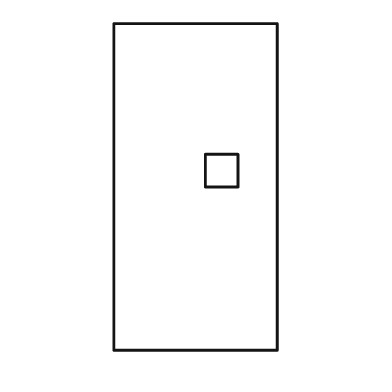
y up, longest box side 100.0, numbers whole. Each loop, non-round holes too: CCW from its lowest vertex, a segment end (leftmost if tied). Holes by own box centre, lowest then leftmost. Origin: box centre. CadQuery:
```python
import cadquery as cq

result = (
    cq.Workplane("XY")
    .moveTo(-25.0, -50.0)
    .lineTo(25.0, -50.0)
    .lineTo(25.0, 50.0)
    .lineTo(-25.0, 50.0)
    .close()
    .moveTo(3.0, 0.0)
    .lineTo(13.0, 0.0)
    .lineTo(13.0, 10.0)
    .lineTo(3.0, 10.0)
    .close()
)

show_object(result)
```